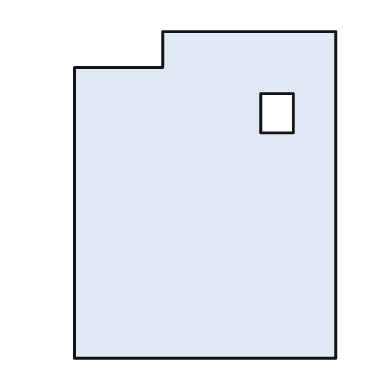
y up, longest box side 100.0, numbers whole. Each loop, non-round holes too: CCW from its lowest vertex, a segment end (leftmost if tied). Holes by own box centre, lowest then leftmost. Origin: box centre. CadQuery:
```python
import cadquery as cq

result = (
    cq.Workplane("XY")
    .moveTo(-40.0, -50.0)
    .lineTo(40.0, -50.0)
    .lineTo(40.0, 50.0)
    .lineTo(-13.0, 50.0)
    .lineTo(-13.0, 39.0)
    .lineTo(-40.0, 39.0)
    .close()
    .moveTo(17.0, 19.0)
    .lineTo(27.0, 19.0)
    .lineTo(27.0, 31.0)
    .lineTo(17.0, 31.0)
    .close()
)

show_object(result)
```